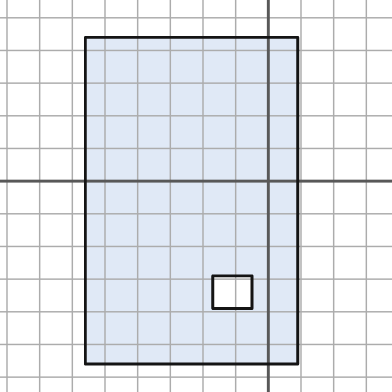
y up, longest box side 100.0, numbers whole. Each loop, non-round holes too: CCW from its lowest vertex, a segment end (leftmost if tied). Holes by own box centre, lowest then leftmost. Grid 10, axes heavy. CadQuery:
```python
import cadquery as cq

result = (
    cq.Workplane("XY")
    .moveTo(-56.0, -56.0)
    .lineTo(9.0, -56.0)
    .lineTo(9.0, 44.0)
    .lineTo(-56.0, 44.0)
    .close()
    .moveTo(-17.0, -39.0)
    .lineTo(-5.0, -39.0)
    .lineTo(-5.0, -29.0)
    .lineTo(-17.0, -29.0)
    .close()
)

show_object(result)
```